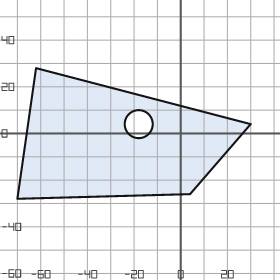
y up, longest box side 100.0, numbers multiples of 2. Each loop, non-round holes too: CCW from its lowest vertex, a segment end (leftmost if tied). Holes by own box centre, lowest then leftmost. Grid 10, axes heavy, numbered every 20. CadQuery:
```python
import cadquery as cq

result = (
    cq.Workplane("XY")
    .moveTo(-70.0, -28.0)
    .lineTo(4.0, -26.0)
    .lineTo(30.0, 4.0)
    .lineTo(-62.0, 28.0)
    .close()
    .moveTo(-18.0, 4.0)
    .circle(6.0)
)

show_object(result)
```